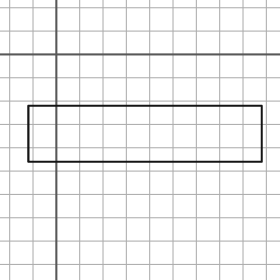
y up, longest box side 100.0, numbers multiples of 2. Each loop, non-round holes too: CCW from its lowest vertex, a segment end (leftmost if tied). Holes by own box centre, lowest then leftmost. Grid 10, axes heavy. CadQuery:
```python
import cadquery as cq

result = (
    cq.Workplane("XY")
    .moveTo(-12.0, -46.0)
    .lineTo(88.0, -46.0)
    .lineTo(88.0, -22.0)
    .lineTo(-12.0, -22.0)
    .close()
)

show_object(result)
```